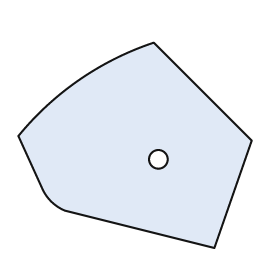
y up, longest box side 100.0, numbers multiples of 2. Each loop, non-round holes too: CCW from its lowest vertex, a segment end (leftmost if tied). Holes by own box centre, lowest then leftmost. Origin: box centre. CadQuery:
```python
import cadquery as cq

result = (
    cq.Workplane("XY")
    .moveTo(34.0, -44.0)
    .lineTo(50.0, 2.0)
    .lineTo(8.0, 44.0)
    .threePointArc((-24.0, 28.0), (-50.0, 4.0))
    .lineTo(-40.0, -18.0)
    .threePointArc((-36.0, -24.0), (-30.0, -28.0))
    .close()
    .moveTo(10.0, -6.0)
    .circle(4.0)
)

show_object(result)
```